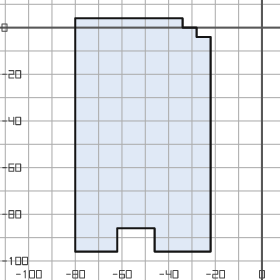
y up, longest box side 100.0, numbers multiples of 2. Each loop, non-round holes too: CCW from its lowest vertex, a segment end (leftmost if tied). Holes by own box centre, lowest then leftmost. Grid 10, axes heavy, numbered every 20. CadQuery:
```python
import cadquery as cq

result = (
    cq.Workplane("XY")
    .moveTo(-80.0, -96.0)
    .lineTo(-62.0, -96.0)
    .lineTo(-62.0, -86.0)
    .lineTo(-46.0, -86.0)
    .lineTo(-46.0, -96.0)
    .lineTo(-22.0, -96.0)
    .lineTo(-22.0, -4.0)
    .lineTo(-28.0, -4.0)
    .lineTo(-28.0, 0.0)
    .lineTo(-34.0, 0.0)
    .lineTo(-34.0, 4.0)
    .lineTo(-80.0, 4.0)
    .close()
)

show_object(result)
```